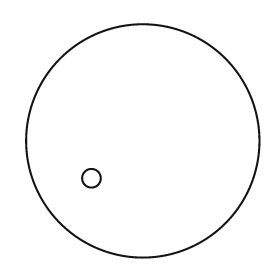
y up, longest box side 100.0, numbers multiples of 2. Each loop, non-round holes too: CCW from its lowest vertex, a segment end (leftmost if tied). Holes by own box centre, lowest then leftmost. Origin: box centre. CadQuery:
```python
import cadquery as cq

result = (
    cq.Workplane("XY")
    .moveTo(0.0, 0.0)
    .circle(50.0)
    .moveTo(-22.0, -16.0)
    .circle(4.0)
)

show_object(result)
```